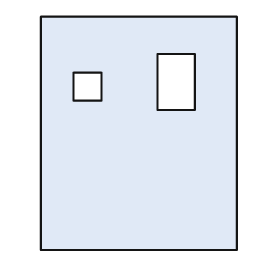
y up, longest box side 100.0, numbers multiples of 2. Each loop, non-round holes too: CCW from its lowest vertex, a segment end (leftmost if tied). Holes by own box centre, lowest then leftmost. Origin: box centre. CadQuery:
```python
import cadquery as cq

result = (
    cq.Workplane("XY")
    .moveTo(-42.0, -50.0)
    .lineTo(42.0, -50.0)
    .lineTo(42.0, 50.0)
    .lineTo(-42.0, 50.0)
    .close()
    .moveTo(-28.0, 14.0)
    .lineTo(-16.0, 14.0)
    .lineTo(-16.0, 26.0)
    .lineTo(-28.0, 26.0)
    .close()
    .moveTo(8.0, 10.0)
    .lineTo(24.0, 10.0)
    .lineTo(24.0, 34.0)
    .lineTo(8.0, 34.0)
    .close()
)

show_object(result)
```